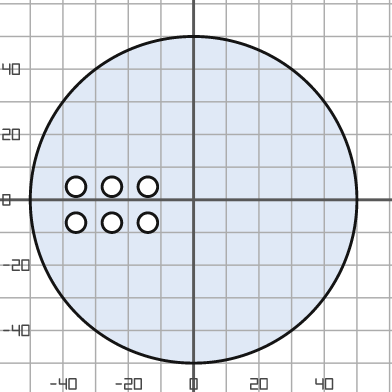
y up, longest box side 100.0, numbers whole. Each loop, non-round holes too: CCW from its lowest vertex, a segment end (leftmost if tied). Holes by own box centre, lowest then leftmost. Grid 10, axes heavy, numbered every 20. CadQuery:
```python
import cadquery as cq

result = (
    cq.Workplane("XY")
    .moveTo(0.0, 0.0)
    .circle(50.0)
    .moveTo(-36.0, -7.0)
    .circle(3.0)
    .moveTo(-25.0, -7.0)
    .circle(3.0)
    .moveTo(-14.0, -7.0)
    .circle(3.0)
    .moveTo(-36.0, 4.0)
    .circle(3.0)
    .moveTo(-25.0, 4.0)
    .circle(3.0)
    .moveTo(-14.0, 4.0)
    .circle(3.0)
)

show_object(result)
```